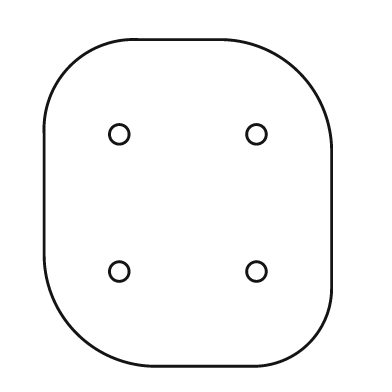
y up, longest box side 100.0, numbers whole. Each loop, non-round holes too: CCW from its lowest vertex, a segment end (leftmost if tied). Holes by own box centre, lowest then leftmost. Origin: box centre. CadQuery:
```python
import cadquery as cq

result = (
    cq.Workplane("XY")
    .moveTo(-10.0, -50.0)
    .lineTo(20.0, -50.0)
    .threePointArc((37.0, -43.0), (44.0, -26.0))
    .lineTo(44.0, 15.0)
    .threePointArc((34.0, 40.0), (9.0, 50.0))
    .lineTo(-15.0, 50.0)
    .threePointArc((-36.0, 42.0), (-44.0, 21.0))
    .lineTo(-44.0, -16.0)
    .threePointArc((-34.0, -40.0), (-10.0, -50.0))
    .close()
    .moveTo(-21.0, -21.0)
    .circle(3.0)
    .moveTo(21.0, -21.0)
    .circle(3.0)
    .moveTo(-21.0, 21.0)
    .circle(3.0)
    .moveTo(21.0, 21.0)
    .circle(3.0)
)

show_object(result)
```